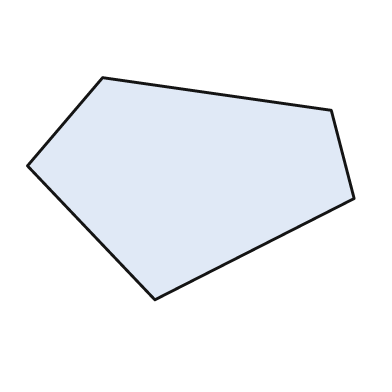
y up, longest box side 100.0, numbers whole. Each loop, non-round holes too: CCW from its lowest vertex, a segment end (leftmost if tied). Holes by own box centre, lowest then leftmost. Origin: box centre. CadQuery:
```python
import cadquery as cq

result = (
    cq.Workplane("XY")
    .moveTo(-11.0, -34.0)
    .lineTo(50.0, -3.0)
    .lineTo(43.0, 24.0)
    .lineTo(-27.0, 34.0)
    .lineTo(-50.0, 7.0)
    .close()
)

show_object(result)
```